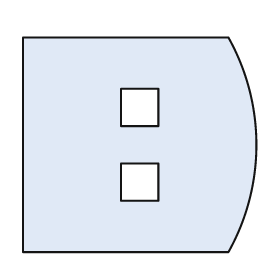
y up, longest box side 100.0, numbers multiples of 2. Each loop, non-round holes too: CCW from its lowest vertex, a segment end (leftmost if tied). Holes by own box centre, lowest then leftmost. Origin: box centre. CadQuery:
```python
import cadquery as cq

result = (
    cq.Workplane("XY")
    .moveTo(-50.0, -46.0)
    .lineTo(38.0, -46.0)
    .threePointArc((50.0, 0.0), (38.0, 46.0))
    .lineTo(-50.0, 46.0)
    .close()
    .moveTo(-8.0, -24.0)
    .lineTo(8.0, -24.0)
    .lineTo(8.0, -8.0)
    .lineTo(-8.0, -8.0)
    .close()
    .moveTo(-8.0, 8.0)
    .lineTo(8.0, 8.0)
    .lineTo(8.0, 24.0)
    .lineTo(-8.0, 24.0)
    .close()
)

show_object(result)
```